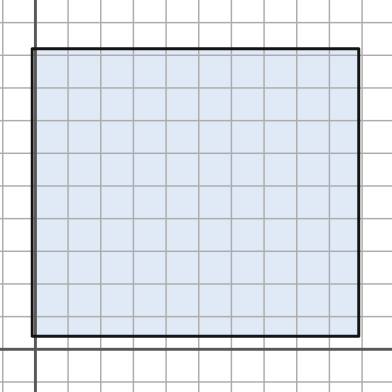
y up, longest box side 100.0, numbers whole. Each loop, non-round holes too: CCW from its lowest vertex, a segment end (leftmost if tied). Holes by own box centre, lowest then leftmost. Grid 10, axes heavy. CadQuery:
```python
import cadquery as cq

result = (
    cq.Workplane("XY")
    .moveTo(-1.0, 4.0)
    .lineTo(99.0, 4.0)
    .lineTo(99.0, 92.0)
    .lineTo(-1.0, 92.0)
    .close()
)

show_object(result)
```